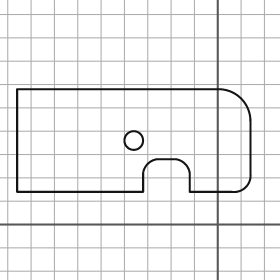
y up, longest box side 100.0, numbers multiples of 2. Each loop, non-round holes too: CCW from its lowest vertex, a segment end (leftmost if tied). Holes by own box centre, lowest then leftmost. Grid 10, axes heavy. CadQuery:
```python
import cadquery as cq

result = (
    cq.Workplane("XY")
    .moveTo(-86.0, 14.0)
    .lineTo(-32.0, 14.0)
    .lineTo(-32.0, 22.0)
    .threePointArc((-30.0, 26.0), (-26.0, 28.0))
    .lineTo(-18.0, 28.0)
    .threePointArc((-14.0, 26.0), (-12.0, 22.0))
    .lineTo(-12.0, 14.0)
    .lineTo(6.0, 14.0)
    .threePointArc((12.0, 16.0), (14.0, 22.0))
    .lineTo(14.0, 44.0)
    .threePointArc((10.0, 54.0), (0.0, 58.0))
    .lineTo(-86.0, 58.0)
    .close()
    .moveTo(-36.0, 36.0)
    .circle(4.0)
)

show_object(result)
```